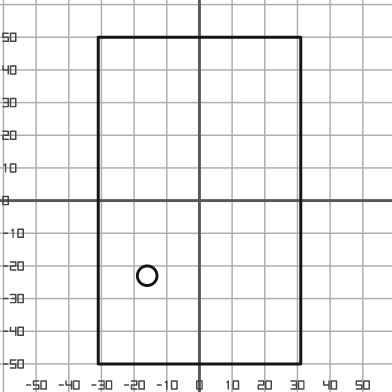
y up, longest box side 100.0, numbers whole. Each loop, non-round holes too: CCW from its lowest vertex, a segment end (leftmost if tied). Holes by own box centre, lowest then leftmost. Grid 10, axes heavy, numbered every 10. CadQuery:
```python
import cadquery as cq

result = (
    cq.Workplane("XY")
    .moveTo(-31.0, -50.0)
    .lineTo(31.0, -50.0)
    .lineTo(31.0, 50.0)
    .lineTo(-31.0, 50.0)
    .close()
    .moveTo(-16.0, -23.0)
    .circle(3.0)
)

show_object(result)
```